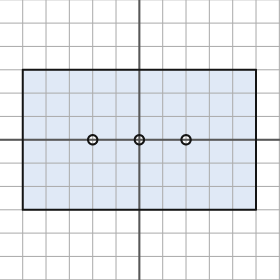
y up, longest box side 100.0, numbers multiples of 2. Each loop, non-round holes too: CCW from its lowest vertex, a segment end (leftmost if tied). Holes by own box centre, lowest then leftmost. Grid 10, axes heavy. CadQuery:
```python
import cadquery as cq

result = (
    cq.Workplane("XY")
    .moveTo(-50.0, -30.0)
    .lineTo(50.0, -30.0)
    .lineTo(50.0, 30.0)
    .lineTo(-50.0, 30.0)
    .close()
    .moveTo(-20.0, 0.0)
    .circle(2.0)
    .moveTo(0.0, 0.0)
    .circle(2.0)
    .moveTo(20.0, 0.0)
    .circle(2.0)
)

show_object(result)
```